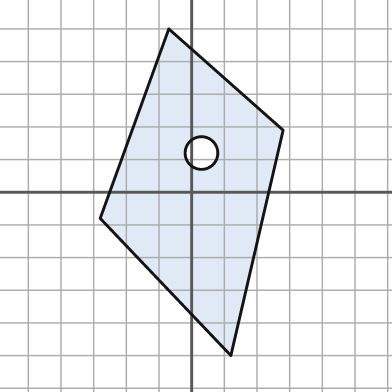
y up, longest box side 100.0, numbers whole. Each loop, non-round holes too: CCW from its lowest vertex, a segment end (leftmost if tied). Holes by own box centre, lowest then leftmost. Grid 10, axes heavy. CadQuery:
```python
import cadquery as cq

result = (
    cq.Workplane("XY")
    .moveTo(12.0, -50.0)
    .lineTo(28.0, 19.0)
    .lineTo(-7.0, 50.0)
    .lineTo(-28.0, -8.0)
    .close()
    .moveTo(3.0, 12.0)
    .circle(5.0)
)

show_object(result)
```